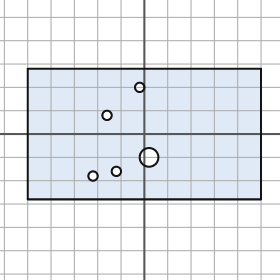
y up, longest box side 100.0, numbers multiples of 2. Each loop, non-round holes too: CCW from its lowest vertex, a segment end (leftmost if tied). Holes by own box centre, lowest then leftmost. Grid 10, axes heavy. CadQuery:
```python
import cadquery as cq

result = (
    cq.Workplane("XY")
    .moveTo(-50.0, -28.0)
    .lineTo(50.0, -28.0)
    .lineTo(50.0, 28.0)
    .lineTo(-50.0, 28.0)
    .close()
    .moveTo(-22.0, -18.0)
    .circle(2.0)
    .moveTo(-12.0, -16.0)
    .circle(2.0)
    .moveTo(2.0, -10.0)
    .circle(4.0)
    .moveTo(-16.0, 8.0)
    .circle(2.0)
    .moveTo(-2.0, 20.0)
    .circle(2.0)
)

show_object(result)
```